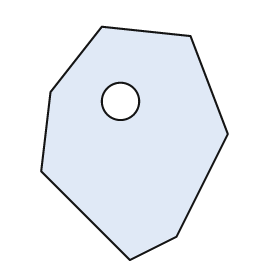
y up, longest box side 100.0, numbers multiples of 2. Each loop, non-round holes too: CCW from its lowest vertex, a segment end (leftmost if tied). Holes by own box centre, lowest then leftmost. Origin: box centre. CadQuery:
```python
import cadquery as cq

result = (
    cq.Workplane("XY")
    .moveTo(-2.0, -50.0)
    .lineTo(18.0, -40.0)
    .lineTo(40.0, 4.0)
    .lineTo(24.0, 46.0)
    .lineTo(-14.0, 50.0)
    .lineTo(-36.0, 22.0)
    .lineTo(-40.0, -12.0)
    .close()
    .moveTo(-6.0, 18.0)
    .circle(8.0)
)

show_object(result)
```